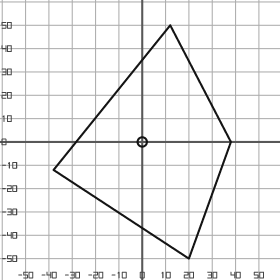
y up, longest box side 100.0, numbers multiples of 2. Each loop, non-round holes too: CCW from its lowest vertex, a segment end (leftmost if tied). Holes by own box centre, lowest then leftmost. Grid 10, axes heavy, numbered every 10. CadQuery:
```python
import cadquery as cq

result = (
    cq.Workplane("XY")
    .moveTo(20.0, -50.0)
    .lineTo(38.0, 0.0)
    .lineTo(12.0, 50.0)
    .lineTo(-38.0, -12.0)
    .close()
    .moveTo(0.0, 0.0)
    .circle(2.0)
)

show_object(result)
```